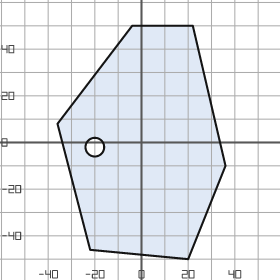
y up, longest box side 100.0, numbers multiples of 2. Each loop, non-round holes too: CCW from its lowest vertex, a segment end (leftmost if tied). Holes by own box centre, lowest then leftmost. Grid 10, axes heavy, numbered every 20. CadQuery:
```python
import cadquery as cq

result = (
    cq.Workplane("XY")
    .moveTo(20.0, -50.0)
    .lineTo(36.0, -10.0)
    .lineTo(22.0, 50.0)
    .lineTo(-4.0, 50.0)
    .lineTo(-36.0, 8.0)
    .lineTo(-22.0, -46.0)
    .close()
    .moveTo(-20.0, -2.0)
    .circle(4.0)
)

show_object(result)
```